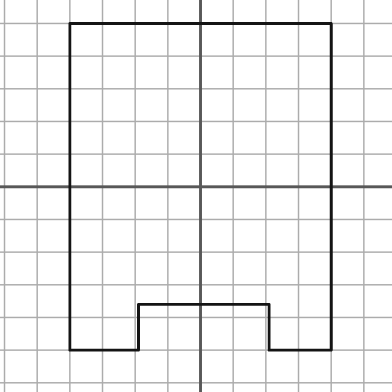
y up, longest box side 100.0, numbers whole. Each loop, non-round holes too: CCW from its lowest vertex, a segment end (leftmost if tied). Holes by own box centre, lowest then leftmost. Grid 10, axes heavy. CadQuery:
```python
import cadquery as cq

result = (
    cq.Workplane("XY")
    .moveTo(-40.0, -50.0)
    .lineTo(-19.0, -50.0)
    .lineTo(-19.0, -36.0)
    .lineTo(21.0, -36.0)
    .lineTo(21.0, -50.0)
    .lineTo(40.0, -50.0)
    .lineTo(40.0, 50.0)
    .lineTo(-40.0, 50.0)
    .close()
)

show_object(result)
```